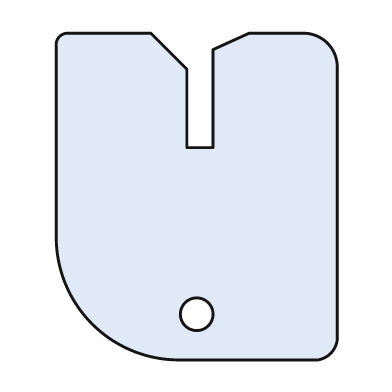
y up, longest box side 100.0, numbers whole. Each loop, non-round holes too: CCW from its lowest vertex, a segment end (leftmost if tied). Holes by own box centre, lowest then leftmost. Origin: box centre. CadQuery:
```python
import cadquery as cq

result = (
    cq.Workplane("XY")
    .moveTo(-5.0, -50.0)
    .lineTo(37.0, -50.0)
    .threePointArc((41.0, -48.0), (43.0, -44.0))
    .lineTo(43.0, 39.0)
    .threePointArc((40.0, 47.0), (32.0, 50.0))
    .lineTo(16.0, 50.0)
    .lineTo(5.0, 45.0)
    .lineTo(5.0, 15.0)
    .lineTo(-3.0, 15.0)
    .lineTo(-3.0, 39.0)
    .lineTo(-14.0, 50.0)
    .lineTo(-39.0, 50.0)
    .threePointArc((-42.0, 49.0), (-43.0, 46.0))
    .lineTo(-43.0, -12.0)
    .threePointArc((-32.0, -39.0), (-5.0, -50.0))
    .close()
    .moveTo(0.0, -36.0)
    .circle(5.0)
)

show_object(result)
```